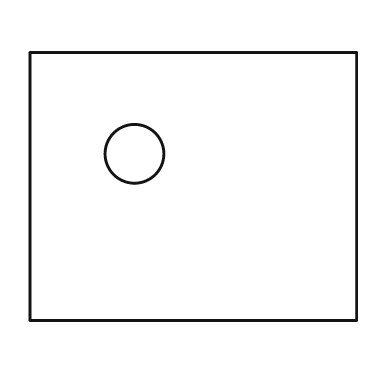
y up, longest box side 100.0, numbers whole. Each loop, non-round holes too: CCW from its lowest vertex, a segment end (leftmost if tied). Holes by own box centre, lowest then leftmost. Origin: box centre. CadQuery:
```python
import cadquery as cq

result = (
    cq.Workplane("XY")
    .moveTo(-50.0, -41.0)
    .lineTo(50.0, -41.0)
    .lineTo(50.0, 41.0)
    .lineTo(-50.0, 41.0)
    .close()
    .moveTo(-18.0, 10.0)
    .circle(9.0)
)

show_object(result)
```